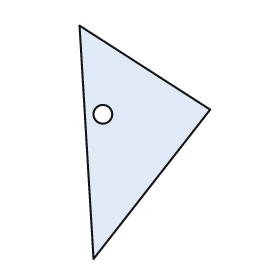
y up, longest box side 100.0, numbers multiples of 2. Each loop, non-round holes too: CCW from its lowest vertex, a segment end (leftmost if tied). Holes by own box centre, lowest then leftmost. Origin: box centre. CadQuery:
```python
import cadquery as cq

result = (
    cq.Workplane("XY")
    .moveTo(-22.0, -50.0)
    .lineTo(28.0, 14.0)
    .lineTo(-28.0, 50.0)
    .close()
    .moveTo(-18.0, 12.0)
    .circle(4.0)
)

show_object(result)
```